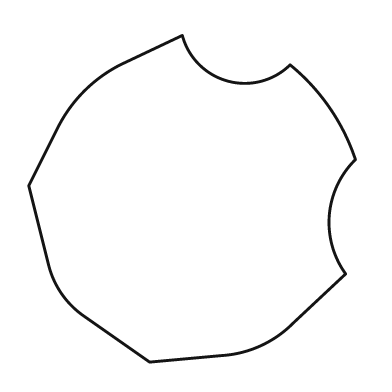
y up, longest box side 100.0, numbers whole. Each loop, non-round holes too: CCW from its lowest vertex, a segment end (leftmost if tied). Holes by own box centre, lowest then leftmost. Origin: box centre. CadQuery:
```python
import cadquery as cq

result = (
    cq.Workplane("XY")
    .moveTo(-13.0, -50.0)
    .lineTo(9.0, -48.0)
    .threePointArc((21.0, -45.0), (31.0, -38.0))
    .lineTo(47.0, -23.0)
    .threePointArc((42.0, -5.0), (50.0, 12.0))
    .threePointArc((42.0, 28.0), (30.0, 41.0))
    .threePointArc((11.0, 36.0), (-3.0, 50.0))
    .lineTo(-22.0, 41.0)
    .threePointArc((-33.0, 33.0), (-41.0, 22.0))
    .lineTo(-50.0, 4.0)
    .lineTo(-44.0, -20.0)
    .threePointArc((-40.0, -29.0), (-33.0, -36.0))
    .close()
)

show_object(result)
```